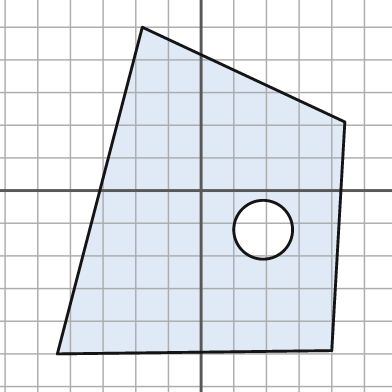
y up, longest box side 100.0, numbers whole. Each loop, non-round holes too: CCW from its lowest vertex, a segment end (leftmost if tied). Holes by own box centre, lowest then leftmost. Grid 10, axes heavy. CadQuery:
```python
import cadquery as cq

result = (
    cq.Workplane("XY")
    .moveTo(-44.0, -50.0)
    .lineTo(40.0, -49.0)
    .lineTo(44.0, 21.0)
    .lineTo(-18.0, 50.0)
    .close()
    .moveTo(19.0, -12.0)
    .circle(9.0)
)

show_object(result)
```